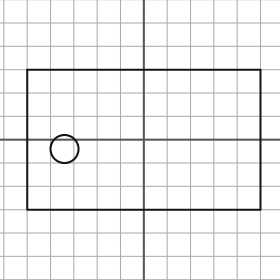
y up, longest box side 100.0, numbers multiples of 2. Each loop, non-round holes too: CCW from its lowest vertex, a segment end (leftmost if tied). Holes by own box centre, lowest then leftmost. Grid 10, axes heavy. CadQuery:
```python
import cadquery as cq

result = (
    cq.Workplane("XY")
    .moveTo(-50.0, -30.0)
    .lineTo(50.0, -30.0)
    .lineTo(50.0, 30.0)
    .lineTo(-50.0, 30.0)
    .close()
    .moveTo(-34.0, -4.0)
    .circle(6.0)
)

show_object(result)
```